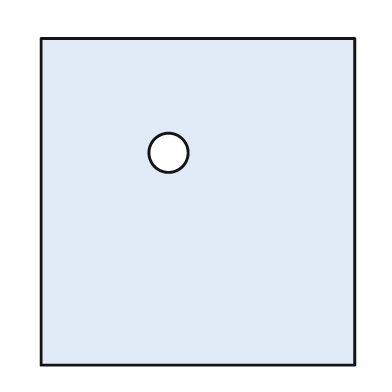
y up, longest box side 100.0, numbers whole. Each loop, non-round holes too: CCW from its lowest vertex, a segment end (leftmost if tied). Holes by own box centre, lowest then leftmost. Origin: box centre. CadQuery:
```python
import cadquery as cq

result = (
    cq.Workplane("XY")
    .moveTo(-48.0, -50.0)
    .lineTo(48.0, -50.0)
    .lineTo(48.0, 50.0)
    .lineTo(-48.0, 50.0)
    .close()
    .moveTo(-9.0, 15.0)
    .circle(6.0)
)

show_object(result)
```